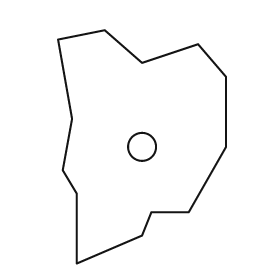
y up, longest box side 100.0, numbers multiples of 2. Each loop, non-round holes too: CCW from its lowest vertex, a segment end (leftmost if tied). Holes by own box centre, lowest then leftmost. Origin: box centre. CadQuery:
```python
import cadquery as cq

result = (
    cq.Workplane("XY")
    .moveTo(-28.0, -50.0)
    .lineTo(0.0, -38.0)
    .lineTo(4.0, -28.0)
    .lineTo(20.0, -28.0)
    .lineTo(36.0, 0.0)
    .lineTo(36.0, 30.0)
    .lineTo(24.0, 44.0)
    .lineTo(0.0, 36.0)
    .lineTo(-16.0, 50.0)
    .lineTo(-36.0, 46.0)
    .lineTo(-30.0, 12.0)
    .lineTo(-34.0, -10.0)
    .lineTo(-28.0, -20.0)
    .close()
    .moveTo(0.0, 0.0)
    .circle(6.0)
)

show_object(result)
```